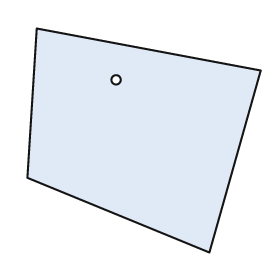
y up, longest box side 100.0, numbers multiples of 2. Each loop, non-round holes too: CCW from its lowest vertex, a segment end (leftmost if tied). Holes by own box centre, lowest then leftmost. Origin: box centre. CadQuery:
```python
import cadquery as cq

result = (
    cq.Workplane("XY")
    .moveTo(28.0, -48.0)
    .lineTo(50.0, 30.0)
    .lineTo(-46.0, 48.0)
    .lineTo(-50.0, -16.0)
    .close()
    .moveTo(-12.0, 26.0)
    .circle(2.0)
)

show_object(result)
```